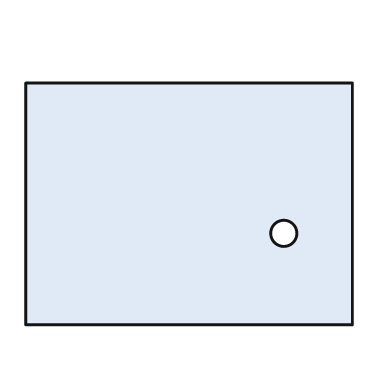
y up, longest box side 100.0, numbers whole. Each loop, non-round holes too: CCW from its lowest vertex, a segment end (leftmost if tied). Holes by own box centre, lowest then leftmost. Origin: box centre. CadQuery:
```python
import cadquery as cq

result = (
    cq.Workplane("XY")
    .moveTo(-50.0, -37.0)
    .lineTo(50.0, -37.0)
    .lineTo(50.0, 37.0)
    .lineTo(-50.0, 37.0)
    .close()
    .moveTo(29.0, -9.0)
    .circle(4.0)
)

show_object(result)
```